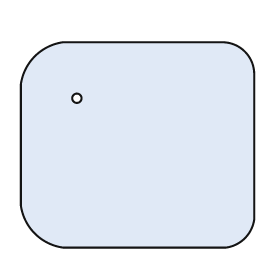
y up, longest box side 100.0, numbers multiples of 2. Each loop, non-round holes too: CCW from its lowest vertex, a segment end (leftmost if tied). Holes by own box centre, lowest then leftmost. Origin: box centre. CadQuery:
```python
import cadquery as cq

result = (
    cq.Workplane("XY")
    .moveTo(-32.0, -44.0)
    .lineTo(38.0, -44.0)
    .threePointArc((46.0, -40.0), (50.0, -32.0))
    .lineTo(50.0, 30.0)
    .threePointArc((46.0, 40.0), (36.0, 44.0))
    .lineTo(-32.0, 44.0)
    .threePointArc((-44.0, 38.0), (-50.0, 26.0))
    .lineTo(-50.0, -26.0)
    .threePointArc((-44.0, -38.0), (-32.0, -44.0))
    .close()
    .moveTo(-26.0, 20.0)
    .circle(2.0)
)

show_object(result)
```